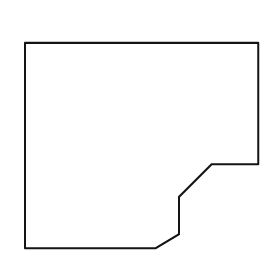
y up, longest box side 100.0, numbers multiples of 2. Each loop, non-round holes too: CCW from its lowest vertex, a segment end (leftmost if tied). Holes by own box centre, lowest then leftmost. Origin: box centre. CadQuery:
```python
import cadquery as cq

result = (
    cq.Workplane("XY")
    .moveTo(-50.0, -44.0)
    .lineTo(6.0, -44.0)
    .lineTo(16.0, -38.0)
    .lineTo(16.0, -22.0)
    .lineTo(30.0, -8.0)
    .lineTo(50.0, -8.0)
    .lineTo(50.0, 44.0)
    .lineTo(-50.0, 44.0)
    .close()
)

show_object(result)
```